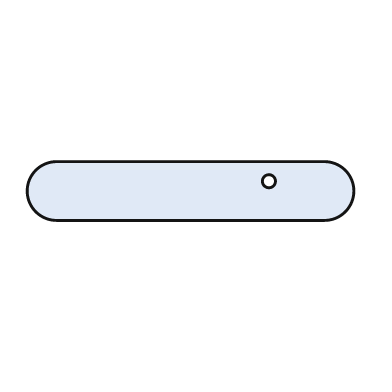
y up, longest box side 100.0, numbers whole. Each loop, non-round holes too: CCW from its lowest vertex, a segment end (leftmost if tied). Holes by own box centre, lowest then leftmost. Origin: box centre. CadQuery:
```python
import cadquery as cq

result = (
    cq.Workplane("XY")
    .moveTo(-41.0, -9.0)
    .lineTo(41.0, -9.0)
    .threePointArc((50.0, 0.0), (41.0, 9.0))
    .lineTo(-41.0, 9.0)
    .threePointArc((-50.0, 0.0), (-41.0, -9.0))
    .close()
    .moveTo(24.0, 3.0)
    .circle(2.0)
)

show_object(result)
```